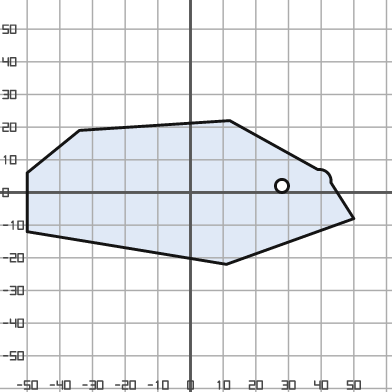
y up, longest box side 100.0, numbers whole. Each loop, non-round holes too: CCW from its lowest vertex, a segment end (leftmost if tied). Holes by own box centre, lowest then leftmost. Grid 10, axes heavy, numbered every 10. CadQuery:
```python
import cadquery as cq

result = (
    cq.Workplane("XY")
    .moveTo(11.0, -22.0)
    .lineTo(50.0, -8.0)
    .lineTo(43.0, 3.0)
    .threePointArc((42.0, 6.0), (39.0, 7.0))
    .lineTo(12.0, 22.0)
    .lineTo(-34.0, 19.0)
    .lineTo(-50.0, 6.0)
    .lineTo(-50.0, -12.0)
    .close()
    .moveTo(28.0, 2.0)
    .circle(2.0)
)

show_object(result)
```